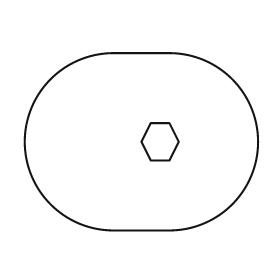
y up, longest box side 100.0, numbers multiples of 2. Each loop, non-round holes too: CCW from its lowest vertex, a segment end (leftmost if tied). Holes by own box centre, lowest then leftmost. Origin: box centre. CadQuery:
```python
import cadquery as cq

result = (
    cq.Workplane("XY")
    .moveTo(-12.0, -38.0)
    .lineTo(12.0, -38.0)
    .threePointArc((50.0, 0.0), (12.0, 38.0))
    .lineTo(-12.0, 38.0)
    .threePointArc((-50.0, 0.0), (-12.0, -38.0))
    .close()
    .moveTo(4.0, -8.0)
    .lineTo(12.0, -8.0)
    .lineTo(16.0, 0.0)
    .lineTo(12.0, 8.0)
    .lineTo(4.0, 8.0)
    .lineTo(0.0, 0.0)
    .close()
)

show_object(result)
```